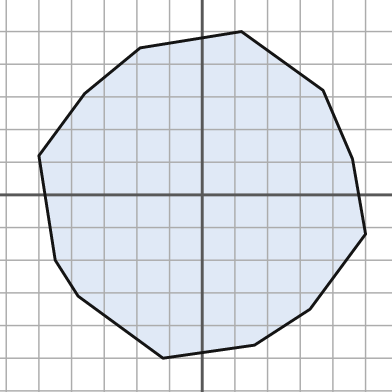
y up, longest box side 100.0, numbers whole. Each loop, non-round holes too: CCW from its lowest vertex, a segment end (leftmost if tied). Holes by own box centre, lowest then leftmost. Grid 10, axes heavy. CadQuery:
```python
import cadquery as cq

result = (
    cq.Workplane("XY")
    .moveTo(-12.0, -50.0)
    .lineTo(16.0, -46.0)
    .lineTo(33.0, -35.0)
    .lineTo(50.0, -12.0)
    .lineTo(46.0, 11.0)
    .lineTo(37.0, 32.0)
    .lineTo(12.0, 50.0)
    .lineTo(-19.0, 45.0)
    .lineTo(-36.0, 31.0)
    .lineTo(-50.0, 12.0)
    .lineTo(-45.0, -20.0)
    .lineTo(-38.0, -31.0)
    .close()
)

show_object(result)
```